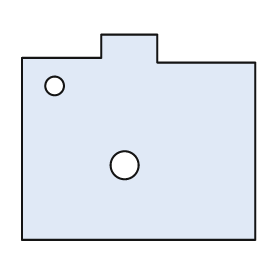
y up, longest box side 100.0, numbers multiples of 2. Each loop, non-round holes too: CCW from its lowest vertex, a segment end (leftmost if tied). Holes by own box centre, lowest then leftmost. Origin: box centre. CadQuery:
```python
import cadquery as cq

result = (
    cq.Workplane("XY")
    .moveTo(-50.0, -44.0)
    .lineTo(50.0, -44.0)
    .lineTo(50.0, 32.0)
    .lineTo(8.0, 32.0)
    .lineTo(8.0, 44.0)
    .lineTo(-16.0, 44.0)
    .lineTo(-16.0, 34.0)
    .lineTo(-50.0, 34.0)
    .close()
    .moveTo(-6.0, -12.0)
    .circle(6.0)
    .moveTo(-36.0, 22.0)
    .circle(4.0)
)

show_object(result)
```